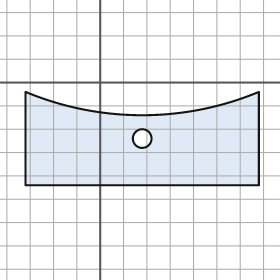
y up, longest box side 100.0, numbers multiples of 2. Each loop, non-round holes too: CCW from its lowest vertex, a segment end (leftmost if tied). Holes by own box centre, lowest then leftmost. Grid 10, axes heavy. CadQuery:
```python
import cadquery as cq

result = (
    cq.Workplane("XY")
    .moveTo(-32.0, -44.0)
    .lineTo(68.0, -44.0)
    .lineTo(68.0, -4.0)
    .threePointArc((18.0, -14.0), (-32.0, -4.0))
    .close()
    .moveTo(18.0, -24.0)
    .circle(4.0)
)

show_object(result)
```